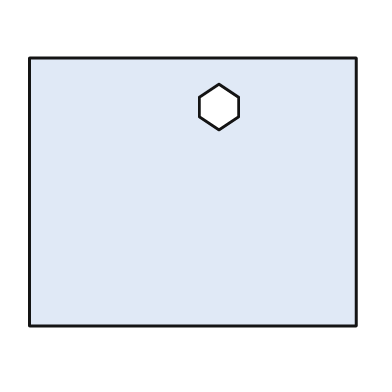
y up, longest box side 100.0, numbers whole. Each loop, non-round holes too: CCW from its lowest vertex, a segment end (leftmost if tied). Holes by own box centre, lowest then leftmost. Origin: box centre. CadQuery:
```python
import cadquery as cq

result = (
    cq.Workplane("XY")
    .moveTo(-50.0, -41.0)
    .lineTo(50.0, -41.0)
    .lineTo(50.0, 41.0)
    .lineTo(-50.0, 41.0)
    .close()
    .moveTo(8.0, 19.0)
    .lineTo(14.0, 23.0)
    .lineTo(14.0, 29.0)
    .lineTo(8.0, 33.0)
    .lineTo(2.0, 29.0)
    .lineTo(2.0, 23.0)
    .close()
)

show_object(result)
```